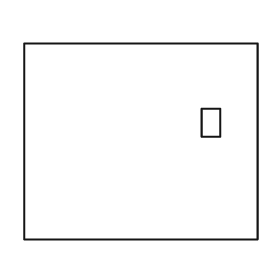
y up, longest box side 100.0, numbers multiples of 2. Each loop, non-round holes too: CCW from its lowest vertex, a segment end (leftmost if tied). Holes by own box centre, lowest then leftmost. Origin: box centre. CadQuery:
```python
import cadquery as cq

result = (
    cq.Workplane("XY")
    .moveTo(-50.0, -42.0)
    .lineTo(50.0, -42.0)
    .lineTo(50.0, 42.0)
    .lineTo(-50.0, 42.0)
    .close()
    .moveTo(26.0, 2.0)
    .lineTo(34.0, 2.0)
    .lineTo(34.0, 14.0)
    .lineTo(26.0, 14.0)
    .close()
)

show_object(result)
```